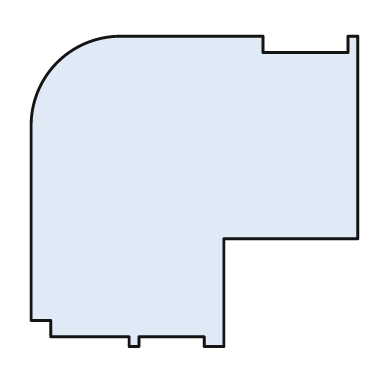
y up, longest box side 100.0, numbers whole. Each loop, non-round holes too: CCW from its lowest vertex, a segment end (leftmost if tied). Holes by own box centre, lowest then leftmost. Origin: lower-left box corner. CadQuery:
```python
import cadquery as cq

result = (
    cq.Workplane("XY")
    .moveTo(30.0, 0.0)
    .lineTo(33.0, 0.0)
    .lineTo(33.0, 3.0)
    .lineTo(53.0, 3.0)
    .lineTo(53.0, 0.0)
    .lineTo(59.0, 0.0)
    .lineTo(59.0, 33.0)
    .lineTo(100.0, 33.0)
    .lineTo(100.0, 95.0)
    .lineTo(97.0, 95.0)
    .lineTo(97.0, 90.0)
    .lineTo(71.0, 90.0)
    .lineTo(71.0, 95.0)
    .lineTo(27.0, 95.0)
    .threePointArc((8.0, 87.0), (0.0, 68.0))
    .lineTo(0.0, 8.0)
    .lineTo(6.0, 8.0)
    .lineTo(6.0, 3.0)
    .lineTo(30.0, 3.0)
    .close()
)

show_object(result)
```